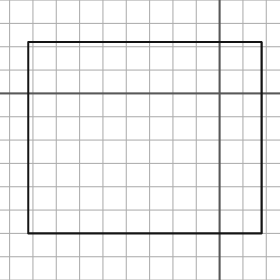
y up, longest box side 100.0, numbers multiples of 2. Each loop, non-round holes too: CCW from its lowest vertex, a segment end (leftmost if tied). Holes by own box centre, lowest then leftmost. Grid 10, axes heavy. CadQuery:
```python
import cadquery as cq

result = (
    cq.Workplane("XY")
    .moveTo(-82.0, -60.0)
    .lineTo(18.0, -60.0)
    .lineTo(18.0, 22.0)
    .lineTo(-82.0, 22.0)
    .close()
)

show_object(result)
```